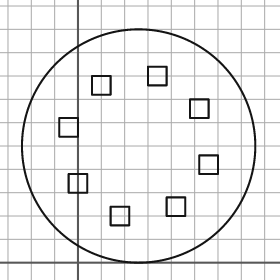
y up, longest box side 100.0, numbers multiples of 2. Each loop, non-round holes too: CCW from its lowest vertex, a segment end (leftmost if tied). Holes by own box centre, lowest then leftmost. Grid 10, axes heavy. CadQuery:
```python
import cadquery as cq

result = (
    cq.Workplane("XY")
    .moveTo(26.0, 50.0)
    .circle(50.0)
    .moveTo(14.0, 16.0)
    .lineTo(22.0, 16.0)
    .lineTo(22.0, 24.0)
    .lineTo(14.0, 24.0)
    .close()
    .moveTo(38.0, 20.0)
    .lineTo(46.0, 20.0)
    .lineTo(46.0, 28.0)
    .lineTo(38.0, 28.0)
    .close()
    .moveTo(-4.0, 30.0)
    .lineTo(4.0, 30.0)
    .lineTo(4.0, 38.0)
    .lineTo(-4.0, 38.0)
    .close()
    .moveTo(52.0, 38.0)
    .lineTo(60.0, 38.0)
    .lineTo(60.0, 46.0)
    .lineTo(52.0, 46.0)
    .close()
    .moveTo(-8.0, 54.0)
    .lineTo(0.0, 54.0)
    .lineTo(0.0, 62.0)
    .lineTo(-8.0, 62.0)
    .close()
    .moveTo(48.0, 62.0)
    .lineTo(56.0, 62.0)
    .lineTo(56.0, 70.0)
    .lineTo(48.0, 70.0)
    .close()
    .moveTo(6.0, 72.0)
    .lineTo(14.0, 72.0)
    .lineTo(14.0, 80.0)
    .lineTo(6.0, 80.0)
    .close()
    .moveTo(30.0, 76.0)
    .lineTo(38.0, 76.0)
    .lineTo(38.0, 84.0)
    .lineTo(30.0, 84.0)
    .close()
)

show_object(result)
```